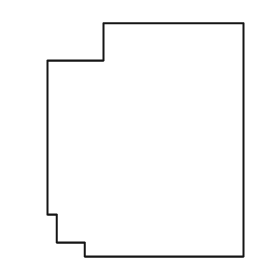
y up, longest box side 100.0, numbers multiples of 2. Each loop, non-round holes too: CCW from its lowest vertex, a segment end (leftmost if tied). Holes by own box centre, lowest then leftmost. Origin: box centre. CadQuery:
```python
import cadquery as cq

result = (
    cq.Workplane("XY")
    .moveTo(-26.0, -50.0)
    .lineTo(42.0, -50.0)
    .lineTo(42.0, 50.0)
    .lineTo(-18.0, 50.0)
    .lineTo(-18.0, 34.0)
    .lineTo(-42.0, 34.0)
    .lineTo(-42.0, -32.0)
    .lineTo(-38.0, -32.0)
    .lineTo(-38.0, -44.0)
    .lineTo(-26.0, -44.0)
    .close()
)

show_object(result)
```